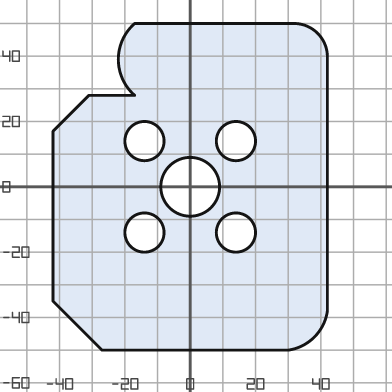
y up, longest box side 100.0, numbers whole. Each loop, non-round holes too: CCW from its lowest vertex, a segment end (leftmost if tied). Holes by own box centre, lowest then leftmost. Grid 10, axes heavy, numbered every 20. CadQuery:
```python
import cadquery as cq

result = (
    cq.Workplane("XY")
    .moveTo(-27.0, -50.0)
    .lineTo(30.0, -50.0)
    .threePointArc((38.0, -46.0), (42.0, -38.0))
    .lineTo(42.0, 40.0)
    .threePointArc((39.0, 47.0), (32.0, 50.0))
    .lineTo(-17.0, 50.0)
    .threePointArc((-22.0, 39.0), (-17.0, 28.0))
    .lineTo(-31.0, 28.0)
    .lineTo(-42.0, 17.0)
    .lineTo(-42.0, -35.0)
    .close()
    .moveTo(-14.0, -14.0)
    .circle(6.0)
    .moveTo(14.0, -14.0)
    .circle(6.0)
    .moveTo(0.0, 0.0)
    .circle(9.0)
    .moveTo(-14.0, 14.0)
    .circle(6.0)
    .moveTo(14.0, 14.0)
    .circle(6.0)
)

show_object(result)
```